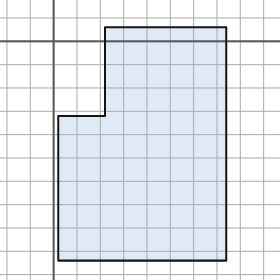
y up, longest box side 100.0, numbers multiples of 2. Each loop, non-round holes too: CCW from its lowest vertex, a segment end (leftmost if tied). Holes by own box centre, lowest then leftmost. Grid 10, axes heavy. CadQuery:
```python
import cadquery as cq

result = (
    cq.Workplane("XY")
    .moveTo(2.0, -94.0)
    .lineTo(74.0, -94.0)
    .lineTo(74.0, 6.0)
    .lineTo(22.0, 6.0)
    .lineTo(22.0, -32.0)
    .lineTo(2.0, -32.0)
    .close()
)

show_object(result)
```